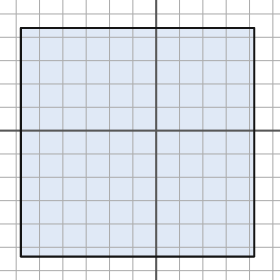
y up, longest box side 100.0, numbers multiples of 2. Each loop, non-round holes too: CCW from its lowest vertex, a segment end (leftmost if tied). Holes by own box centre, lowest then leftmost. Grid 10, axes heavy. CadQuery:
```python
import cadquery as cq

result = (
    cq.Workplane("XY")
    .moveTo(-58.0, -54.0)
    .lineTo(42.0, -54.0)
    .lineTo(42.0, 44.0)
    .lineTo(-58.0, 44.0)
    .close()
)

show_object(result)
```